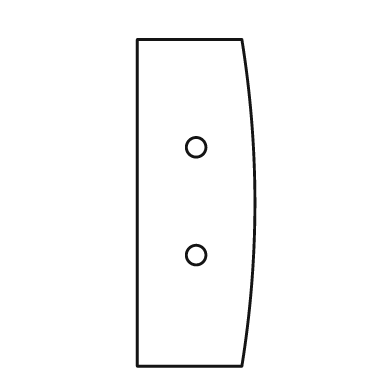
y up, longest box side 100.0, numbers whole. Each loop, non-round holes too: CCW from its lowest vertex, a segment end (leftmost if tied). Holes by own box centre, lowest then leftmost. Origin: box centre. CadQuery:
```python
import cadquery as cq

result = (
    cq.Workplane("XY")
    .moveTo(-18.0, -50.0)
    .lineTo(14.0, -50.0)
    .threePointArc((18.0, 0.0), (14.0, 50.0))
    .lineTo(-18.0, 50.0)
    .close()
    .moveTo(0.0, -16.0)
    .circle(3.0)
    .moveTo(0.0, 17.0)
    .circle(3.0)
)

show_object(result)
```